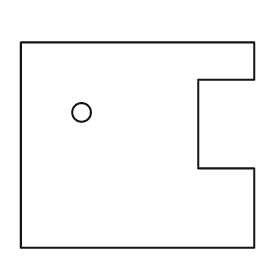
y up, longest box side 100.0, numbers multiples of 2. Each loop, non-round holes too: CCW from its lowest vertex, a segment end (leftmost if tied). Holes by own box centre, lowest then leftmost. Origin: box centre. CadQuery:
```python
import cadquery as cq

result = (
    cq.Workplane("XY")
    .moveTo(-50.0, -44.0)
    .lineTo(50.0, -44.0)
    .lineTo(50.0, -10.0)
    .lineTo(26.0, -10.0)
    .lineTo(26.0, 28.0)
    .lineTo(50.0, 28.0)
    .lineTo(50.0, 44.0)
    .lineTo(-50.0, 44.0)
    .close()
    .moveTo(-24.0, 14.0)
    .circle(4.0)
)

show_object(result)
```